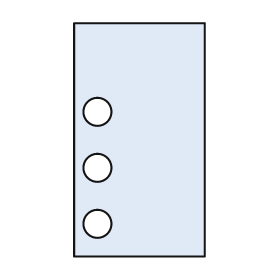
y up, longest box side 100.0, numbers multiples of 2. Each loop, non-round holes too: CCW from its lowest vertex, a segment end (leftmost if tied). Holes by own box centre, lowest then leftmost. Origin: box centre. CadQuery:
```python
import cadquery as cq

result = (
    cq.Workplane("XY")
    .moveTo(-28.0, -50.0)
    .lineTo(28.0, -50.0)
    .lineTo(28.0, 50.0)
    .lineTo(-28.0, 50.0)
    .close()
    .moveTo(-18.0, -36.0)
    .circle(6.0)
    .moveTo(-18.0, -12.0)
    .circle(6.0)
    .moveTo(-18.0, 12.0)
    .circle(6.0)
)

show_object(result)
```